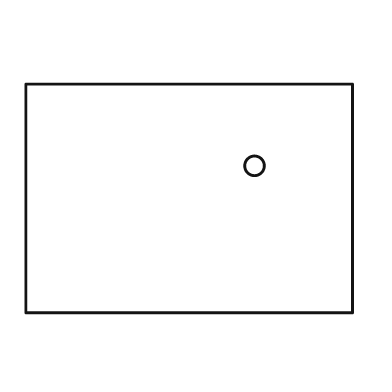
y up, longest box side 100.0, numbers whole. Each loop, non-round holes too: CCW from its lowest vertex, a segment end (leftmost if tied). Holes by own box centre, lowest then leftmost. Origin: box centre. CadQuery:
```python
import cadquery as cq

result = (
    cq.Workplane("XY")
    .moveTo(-50.0, -35.0)
    .lineTo(50.0, -35.0)
    .lineTo(50.0, 35.0)
    .lineTo(-50.0, 35.0)
    .close()
    .moveTo(20.0, 10.0)
    .circle(3.0)
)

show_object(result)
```